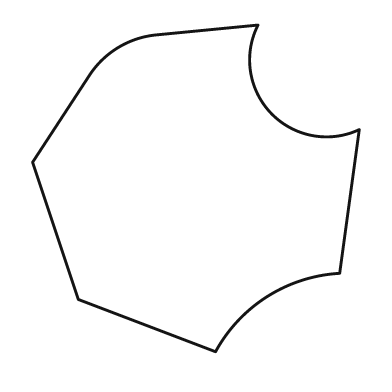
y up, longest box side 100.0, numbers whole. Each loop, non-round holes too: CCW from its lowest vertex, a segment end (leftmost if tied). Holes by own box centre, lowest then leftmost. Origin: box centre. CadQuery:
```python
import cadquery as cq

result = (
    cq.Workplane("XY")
    .moveTo(6.0, -50.0)
    .threePointArc((22.0, -33.0), (44.0, -26.0))
    .lineTo(50.0, 18.0)
    .threePointArc((23.0, 23.0), (19.0, 50.0))
    .lineTo(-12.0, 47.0)
    .threePointArc((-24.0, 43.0), (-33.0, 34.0))
    .lineTo(-50.0, 8.0)
    .lineTo(-36.0, -34.0)
    .close()
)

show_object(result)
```